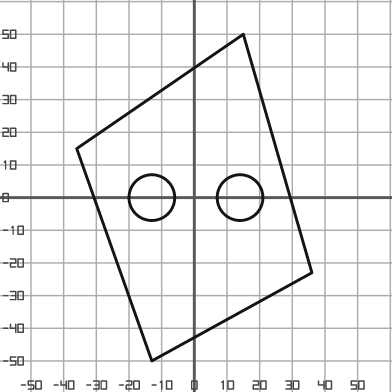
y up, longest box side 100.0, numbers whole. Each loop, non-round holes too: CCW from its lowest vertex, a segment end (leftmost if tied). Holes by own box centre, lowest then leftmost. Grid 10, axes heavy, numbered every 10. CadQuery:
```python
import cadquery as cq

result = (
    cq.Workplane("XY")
    .moveTo(-13.0, -50.0)
    .lineTo(36.0, -23.0)
    .lineTo(15.0, 50.0)
    .lineTo(-36.0, 15.0)
    .close()
    .moveTo(-13.0, 0.0)
    .circle(7.0)
    .moveTo(14.0, 0.0)
    .circle(7.0)
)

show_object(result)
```